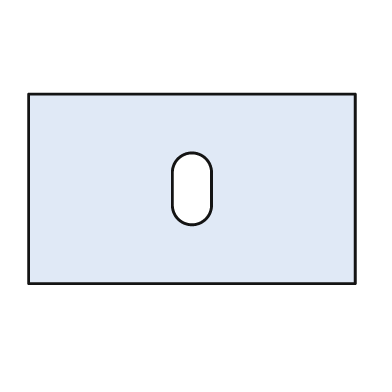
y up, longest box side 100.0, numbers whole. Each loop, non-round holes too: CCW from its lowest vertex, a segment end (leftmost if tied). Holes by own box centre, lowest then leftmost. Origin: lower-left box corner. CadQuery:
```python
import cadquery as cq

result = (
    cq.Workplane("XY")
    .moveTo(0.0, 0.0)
    .lineTo(100.0, 0.0)
    .lineTo(100.0, 58.0)
    .lineTo(0.0, 58.0)
    .close()
    .moveTo(44.0, 24.0)
    .threePointArc((50.0, 18.0), (56.0, 24.0))
    .lineTo(56.0, 34.0)
    .threePointArc((50.0, 40.0), (44.0, 34.0))
    .close()
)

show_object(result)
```